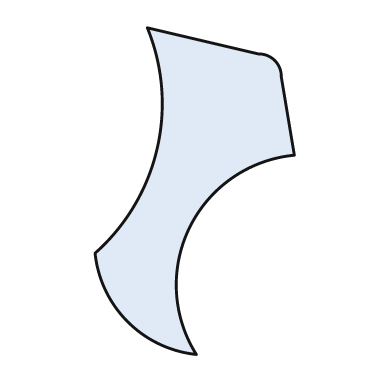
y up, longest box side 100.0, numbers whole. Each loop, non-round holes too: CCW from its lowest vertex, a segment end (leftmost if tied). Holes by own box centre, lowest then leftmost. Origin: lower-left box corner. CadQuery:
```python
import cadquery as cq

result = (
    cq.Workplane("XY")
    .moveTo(31.0, 0.0)
    .threePointArc((29.0, 39.0), (61.0, 61.0))
    .lineTo(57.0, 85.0)
    .threePointArc((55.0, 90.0), (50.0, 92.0))
    .lineTo(16.0, 100.0)
    .threePointArc((19.0, 63.0), (0.0, 31.0))
    .threePointArc((10.0, 10.0), (31.0, 0.0))
    .close()
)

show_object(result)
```